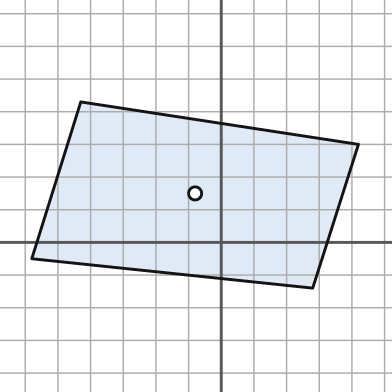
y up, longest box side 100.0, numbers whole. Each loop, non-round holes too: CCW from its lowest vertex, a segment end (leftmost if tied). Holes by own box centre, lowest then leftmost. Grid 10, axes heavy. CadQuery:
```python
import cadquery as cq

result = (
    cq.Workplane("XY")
    .moveTo(28.0, -14.0)
    .lineTo(42.0, 30.0)
    .lineTo(-43.0, 43.0)
    .lineTo(-58.0, -5.0)
    .close()
    .moveTo(-8.0, 15.0)
    .circle(2.0)
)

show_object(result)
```